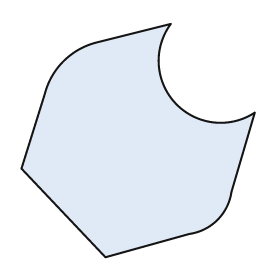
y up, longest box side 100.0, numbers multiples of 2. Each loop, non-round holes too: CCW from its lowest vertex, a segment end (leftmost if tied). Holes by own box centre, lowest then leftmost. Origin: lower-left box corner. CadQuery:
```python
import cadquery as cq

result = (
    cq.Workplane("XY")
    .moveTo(36.0, 0.0)
    .lineTo(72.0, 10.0)
    .threePointArc((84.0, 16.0), (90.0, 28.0))
    .lineTo(100.0, 62.0)
    .threePointArc((66.0, 66.0), (64.0, 100.0))
    .lineTo(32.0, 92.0)
    .threePointArc((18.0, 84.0), (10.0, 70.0))
    .lineTo(0.0, 38.0)
    .close()
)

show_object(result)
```